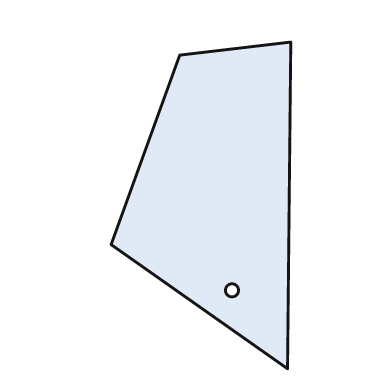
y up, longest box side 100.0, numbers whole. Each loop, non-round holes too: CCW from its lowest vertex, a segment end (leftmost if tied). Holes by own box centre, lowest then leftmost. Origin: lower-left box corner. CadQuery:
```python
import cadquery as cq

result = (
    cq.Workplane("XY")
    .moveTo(54.0, 0.0)
    .lineTo(55.0, 100.0)
    .lineTo(21.0, 96.0)
    .lineTo(0.0, 38.0)
    .close()
    .moveTo(37.0, 24.0)
    .circle(2.0)
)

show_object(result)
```